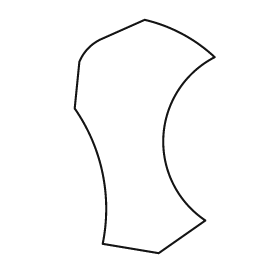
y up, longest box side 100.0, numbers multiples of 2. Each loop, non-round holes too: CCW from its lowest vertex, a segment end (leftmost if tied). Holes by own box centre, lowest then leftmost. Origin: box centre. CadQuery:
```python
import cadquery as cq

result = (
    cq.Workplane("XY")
    .moveTo(6.0, -50.0)
    .lineTo(26.0, -36.0)
    .threePointArc((8.0, 0.0), (30.0, 34.0))
    .threePointArc((16.0, 44.0), (0.0, 50.0))
    .lineTo(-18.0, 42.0)
    .threePointArc((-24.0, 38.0), (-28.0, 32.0))
    .lineTo(-30.0, 12.0)
    .threePointArc((-18.0, -16.0), (-18.0, -46.0))
    .close()
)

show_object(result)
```